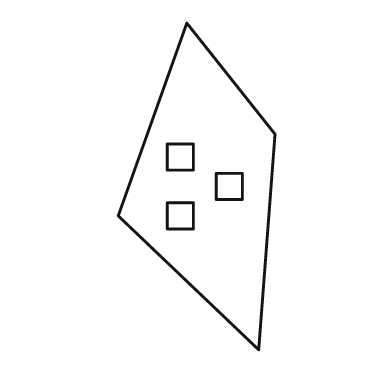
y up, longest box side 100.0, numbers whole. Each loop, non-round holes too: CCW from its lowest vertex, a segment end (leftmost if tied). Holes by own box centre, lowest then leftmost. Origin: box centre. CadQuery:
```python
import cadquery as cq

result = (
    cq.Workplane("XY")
    .moveTo(19.0, -50.0)
    .lineTo(24.0, 16.0)
    .lineTo(-3.0, 50.0)
    .lineTo(-24.0, -9.0)
    .close()
    .moveTo(-9.0, -13.0)
    .lineTo(-1.0, -13.0)
    .lineTo(-1.0, -5.0)
    .lineTo(-9.0, -5.0)
    .close()
    .moveTo(6.0, -4.0)
    .lineTo(14.0, -4.0)
    .lineTo(14.0, 4.0)
    .lineTo(6.0, 4.0)
    .close()
    .moveTo(-9.0, 5.0)
    .lineTo(-1.0, 5.0)
    .lineTo(-1.0, 13.0)
    .lineTo(-9.0, 13.0)
    .close()
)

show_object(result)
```